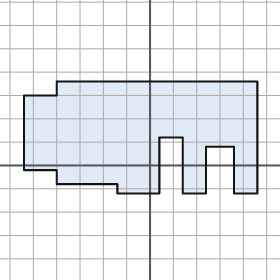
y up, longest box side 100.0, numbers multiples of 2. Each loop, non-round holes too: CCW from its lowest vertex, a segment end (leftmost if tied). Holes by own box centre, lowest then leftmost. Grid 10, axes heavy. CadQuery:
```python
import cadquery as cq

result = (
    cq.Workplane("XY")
    .moveTo(-14.0, -12.0)
    .lineTo(4.0, -12.0)
    .lineTo(4.0, 12.0)
    .lineTo(14.0, 12.0)
    .lineTo(14.0, -12.0)
    .lineTo(24.0, -12.0)
    .lineTo(24.0, 8.0)
    .lineTo(36.0, 8.0)
    .lineTo(36.0, -12.0)
    .lineTo(46.0, -12.0)
    .lineTo(46.0, 36.0)
    .lineTo(-40.0, 36.0)
    .lineTo(-40.0, 30.0)
    .lineTo(-54.0, 30.0)
    .lineTo(-54.0, -2.0)
    .lineTo(-40.0, -2.0)
    .lineTo(-40.0, -8.0)
    .lineTo(-14.0, -8.0)
    .close()
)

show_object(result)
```